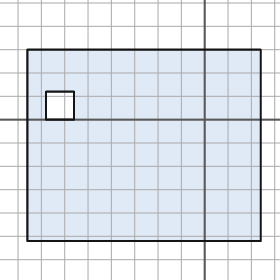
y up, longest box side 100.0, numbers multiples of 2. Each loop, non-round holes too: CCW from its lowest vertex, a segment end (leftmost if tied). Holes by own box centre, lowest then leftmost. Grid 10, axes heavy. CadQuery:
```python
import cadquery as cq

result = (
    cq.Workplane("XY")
    .moveTo(-76.0, -52.0)
    .lineTo(24.0, -52.0)
    .lineTo(24.0, 30.0)
    .lineTo(-76.0, 30.0)
    .close()
    .moveTo(-68.0, 0.0)
    .lineTo(-56.0, 0.0)
    .lineTo(-56.0, 12.0)
    .lineTo(-68.0, 12.0)
    .close()
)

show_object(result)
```